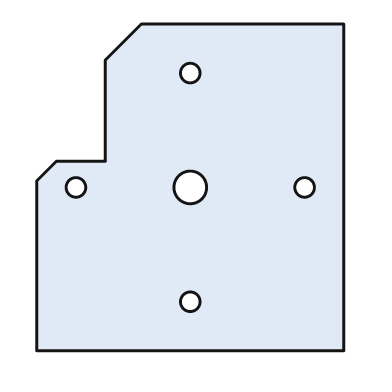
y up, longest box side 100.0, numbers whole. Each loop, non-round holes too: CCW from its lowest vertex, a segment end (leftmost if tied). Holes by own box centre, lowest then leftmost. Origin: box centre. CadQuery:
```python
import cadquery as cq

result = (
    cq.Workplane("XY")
    .moveTo(-47.0, -50.0)
    .lineTo(47.0, -50.0)
    .lineTo(47.0, 50.0)
    .lineTo(-15.0, 50.0)
    .lineTo(-26.0, 39.0)
    .lineTo(-26.0, 8.0)
    .lineTo(-41.0, 8.0)
    .lineTo(-47.0, 2.0)
    .close()
    .moveTo(0.0, -35.0)
    .circle(3.0)
    .moveTo(-35.0, 0.0)
    .circle(3.0)
    .moveTo(0.0, 0.0)
    .circle(5.0)
    .moveTo(35.0, 0.0)
    .circle(3.0)
    .moveTo(0.0, 35.0)
    .circle(3.0)
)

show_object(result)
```